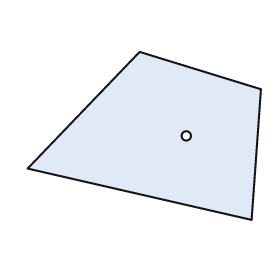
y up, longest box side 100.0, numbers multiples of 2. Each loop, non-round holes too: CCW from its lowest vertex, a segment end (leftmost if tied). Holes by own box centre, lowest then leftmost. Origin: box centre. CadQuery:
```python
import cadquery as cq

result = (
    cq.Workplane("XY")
    .moveTo(46.0, -36.0)
    .lineTo(50.0, 20.0)
    .lineTo(-2.0, 36.0)
    .lineTo(-50.0, -14.0)
    .close()
    .moveTo(18.0, 0.0)
    .circle(2.0)
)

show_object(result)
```